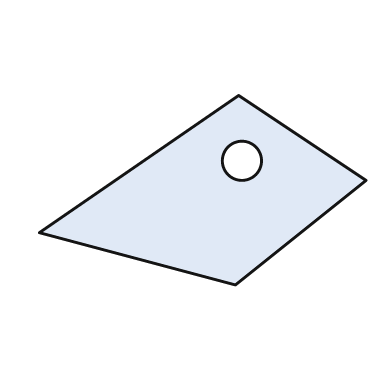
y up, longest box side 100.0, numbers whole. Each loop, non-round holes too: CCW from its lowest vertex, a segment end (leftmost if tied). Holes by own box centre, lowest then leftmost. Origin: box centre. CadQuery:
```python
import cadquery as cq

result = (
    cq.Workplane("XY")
    .moveTo(10.0, -29.0)
    .lineTo(50.0, 3.0)
    .lineTo(11.0, 29.0)
    .lineTo(-50.0, -13.0)
    .close()
    .moveTo(12.0, 9.0)
    .circle(6.0)
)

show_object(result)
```